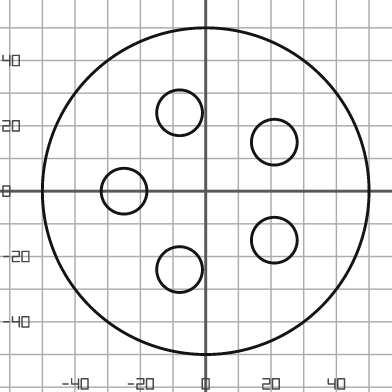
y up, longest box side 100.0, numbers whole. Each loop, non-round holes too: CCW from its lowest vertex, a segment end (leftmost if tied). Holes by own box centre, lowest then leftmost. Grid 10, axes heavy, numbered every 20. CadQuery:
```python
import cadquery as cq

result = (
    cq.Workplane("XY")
    .moveTo(0.0, 0.0)
    .circle(50.0)
    .moveTo(-8.0, -24.0)
    .circle(7.0)
    .moveTo(21.0, -15.0)
    .circle(7.0)
    .moveTo(-25.0, 0.0)
    .circle(7.0)
    .moveTo(21.0, 15.0)
    .circle(7.0)
    .moveTo(-8.0, 24.0)
    .circle(7.0)
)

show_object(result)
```